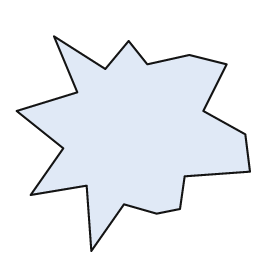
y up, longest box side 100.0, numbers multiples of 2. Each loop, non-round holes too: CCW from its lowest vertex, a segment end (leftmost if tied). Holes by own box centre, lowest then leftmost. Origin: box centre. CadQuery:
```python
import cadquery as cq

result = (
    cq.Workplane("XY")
    .moveTo(-18.0, -46.0)
    .lineTo(-4.0, -26.0)
    .lineTo(10.0, -30.0)
    .lineTo(20.0, -28.0)
    .lineTo(22.0, -14.0)
    .lineTo(50.0, -12.0)
    .lineTo(48.0, 4.0)
    .lineTo(30.0, 14.0)
    .lineTo(40.0, 34.0)
    .lineTo(24.0, 38.0)
    .lineTo(6.0, 34.0)
    .lineTo(-2.0, 44.0)
    .lineTo(-12.0, 32.0)
    .lineTo(-34.0, 46.0)
    .lineTo(-24.0, 22.0)
    .lineTo(-50.0, 14.0)
    .lineTo(-30.0, -2.0)
    .lineTo(-44.0, -22.0)
    .lineTo(-20.0, -18.0)
    .close()
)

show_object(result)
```